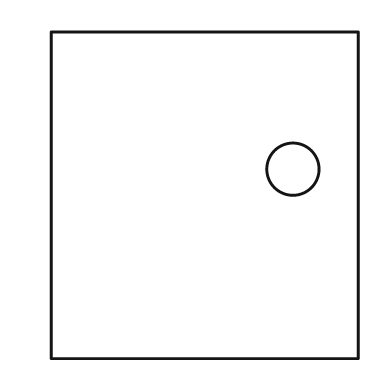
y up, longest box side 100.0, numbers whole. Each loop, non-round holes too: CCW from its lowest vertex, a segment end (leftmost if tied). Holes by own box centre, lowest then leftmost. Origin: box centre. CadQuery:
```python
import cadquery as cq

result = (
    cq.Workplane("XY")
    .moveTo(-47.0, -50.0)
    .lineTo(47.0, -50.0)
    .lineTo(47.0, 50.0)
    .lineTo(-47.0, 50.0)
    .close()
    .moveTo(27.0, 8.0)
    .circle(8.0)
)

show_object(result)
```